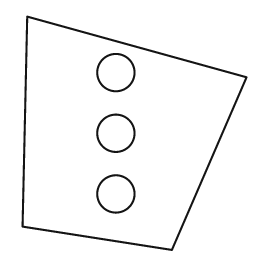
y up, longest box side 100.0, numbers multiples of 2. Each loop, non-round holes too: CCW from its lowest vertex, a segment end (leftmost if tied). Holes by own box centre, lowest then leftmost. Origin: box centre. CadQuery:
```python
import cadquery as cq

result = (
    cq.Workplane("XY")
    .moveTo(16.0, -50.0)
    .lineTo(48.0, 24.0)
    .lineTo(-46.0, 50.0)
    .lineTo(-48.0, -40.0)
    .close()
    .moveTo(-8.0, -26.0)
    .circle(8.0)
    .moveTo(-8.0, 0.0)
    .circle(8.0)
    .moveTo(-8.0, 26.0)
    .circle(8.0)
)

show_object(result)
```